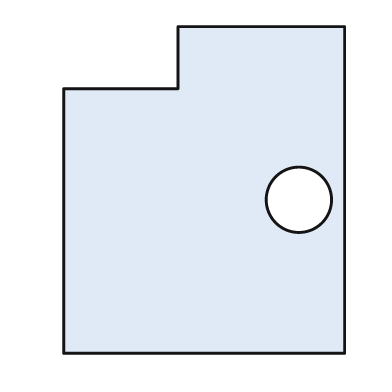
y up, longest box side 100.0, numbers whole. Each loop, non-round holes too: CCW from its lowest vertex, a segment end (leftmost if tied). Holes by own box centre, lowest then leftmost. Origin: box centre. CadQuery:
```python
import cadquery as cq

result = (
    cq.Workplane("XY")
    .moveTo(-43.0, -50.0)
    .lineTo(43.0, -50.0)
    .lineTo(43.0, 50.0)
    .lineTo(-8.0, 50.0)
    .lineTo(-8.0, 31.0)
    .lineTo(-43.0, 31.0)
    .close()
    .moveTo(29.0, -3.0)
    .circle(10.0)
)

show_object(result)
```